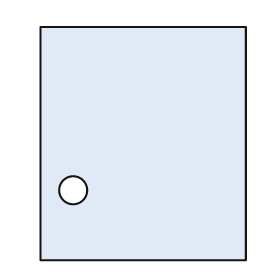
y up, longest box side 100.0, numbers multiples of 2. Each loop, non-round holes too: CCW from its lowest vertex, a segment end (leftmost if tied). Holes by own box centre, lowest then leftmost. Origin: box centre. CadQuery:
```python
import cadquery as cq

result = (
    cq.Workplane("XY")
    .moveTo(-44.0, -50.0)
    .lineTo(44.0, -50.0)
    .lineTo(44.0, 50.0)
    .lineTo(-44.0, 50.0)
    .close()
    .moveTo(-30.0, -20.0)
    .circle(6.0)
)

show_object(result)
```